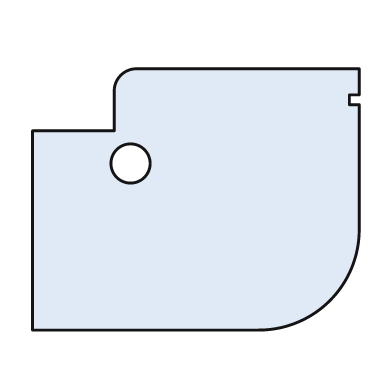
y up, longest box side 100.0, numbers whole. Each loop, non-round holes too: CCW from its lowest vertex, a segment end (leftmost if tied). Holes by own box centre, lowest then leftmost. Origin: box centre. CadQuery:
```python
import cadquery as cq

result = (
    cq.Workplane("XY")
    .moveTo(-50.0, -40.0)
    .lineTo(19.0, -40.0)
    .threePointArc((41.0, -31.0), (50.0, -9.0))
    .lineTo(50.0, 29.0)
    .lineTo(47.0, 29.0)
    .lineTo(47.0, 32.0)
    .lineTo(50.0, 32.0)
    .lineTo(50.0, 40.0)
    .lineTo(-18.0, 40.0)
    .threePointArc((-23.0, 38.0), (-25.0, 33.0))
    .lineTo(-25.0, 21.0)
    .lineTo(-50.0, 21.0)
    .close()
    .moveTo(-20.0, 11.0)
    .circle(6.0)
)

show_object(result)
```